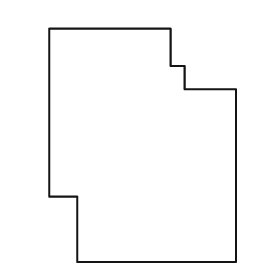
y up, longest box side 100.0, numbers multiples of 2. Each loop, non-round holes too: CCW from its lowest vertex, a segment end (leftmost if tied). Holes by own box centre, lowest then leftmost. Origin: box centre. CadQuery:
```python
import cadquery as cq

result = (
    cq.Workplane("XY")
    .moveTo(-28.0, -50.0)
    .lineTo(40.0, -50.0)
    .lineTo(40.0, 24.0)
    .lineTo(18.0, 24.0)
    .lineTo(18.0, 34.0)
    .lineTo(12.0, 34.0)
    .lineTo(12.0, 50.0)
    .lineTo(-40.0, 50.0)
    .lineTo(-40.0, -22.0)
    .lineTo(-28.0, -22.0)
    .close()
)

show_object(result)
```